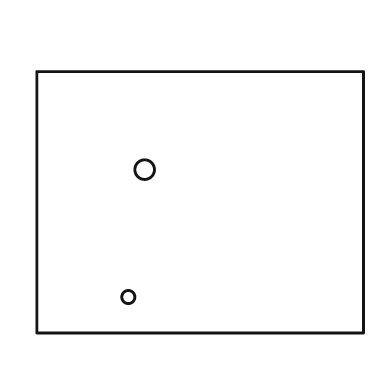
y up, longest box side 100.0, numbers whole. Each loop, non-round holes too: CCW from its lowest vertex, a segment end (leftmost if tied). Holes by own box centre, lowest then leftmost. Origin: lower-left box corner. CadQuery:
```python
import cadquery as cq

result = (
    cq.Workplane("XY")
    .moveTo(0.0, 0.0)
    .lineTo(100.0, 0.0)
    .lineTo(100.0, 80.0)
    .lineTo(0.0, 80.0)
    .close()
    .moveTo(28.0, 11.0)
    .circle(2.0)
    .moveTo(33.0, 50.0)
    .circle(3.0)
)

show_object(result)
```